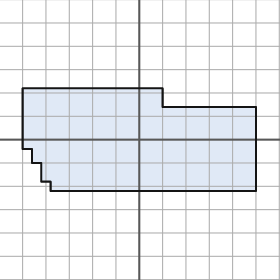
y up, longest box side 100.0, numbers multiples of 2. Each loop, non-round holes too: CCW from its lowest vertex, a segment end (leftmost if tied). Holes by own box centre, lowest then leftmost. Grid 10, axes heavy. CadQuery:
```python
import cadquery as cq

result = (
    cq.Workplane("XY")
    .moveTo(-38.0, -22.0)
    .lineTo(50.0, -22.0)
    .lineTo(50.0, 14.0)
    .lineTo(10.0, 14.0)
    .lineTo(10.0, 22.0)
    .lineTo(-50.0, 22.0)
    .lineTo(-50.0, -4.0)
    .lineTo(-46.0, -4.0)
    .lineTo(-46.0, -10.0)
    .lineTo(-42.0, -10.0)
    .lineTo(-42.0, -18.0)
    .lineTo(-38.0, -18.0)
    .close()
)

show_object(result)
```